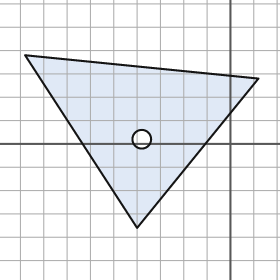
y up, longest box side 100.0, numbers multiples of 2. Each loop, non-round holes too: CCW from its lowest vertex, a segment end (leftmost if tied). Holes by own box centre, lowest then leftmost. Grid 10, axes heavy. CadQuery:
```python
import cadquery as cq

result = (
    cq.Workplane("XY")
    .moveTo(-40.0, -36.0)
    .lineTo(12.0, 28.0)
    .lineTo(-88.0, 38.0)
    .close()
    .moveTo(-38.0, 2.0)
    .circle(4.0)
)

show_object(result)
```